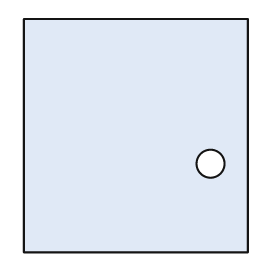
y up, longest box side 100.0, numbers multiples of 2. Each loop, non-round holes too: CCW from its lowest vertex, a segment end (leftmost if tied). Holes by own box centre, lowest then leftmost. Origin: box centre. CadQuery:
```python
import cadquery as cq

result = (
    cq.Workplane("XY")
    .moveTo(-48.0, -50.0)
    .lineTo(48.0, -50.0)
    .lineTo(48.0, 50.0)
    .lineTo(-48.0, 50.0)
    .close()
    .moveTo(32.0, -12.0)
    .circle(6.0)
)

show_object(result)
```